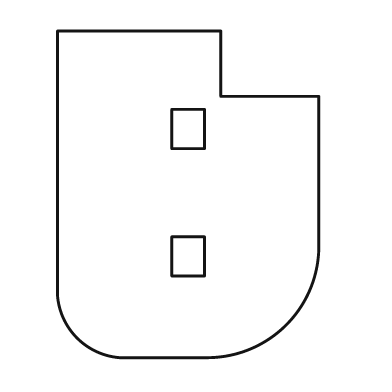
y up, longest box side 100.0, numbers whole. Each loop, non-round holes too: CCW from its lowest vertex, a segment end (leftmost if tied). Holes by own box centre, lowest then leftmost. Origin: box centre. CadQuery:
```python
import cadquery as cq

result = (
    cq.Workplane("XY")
    .moveTo(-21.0, -50.0)
    .lineTo(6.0, -50.0)
    .threePointArc((30.0, -40.0), (40.0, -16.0))
    .lineTo(40.0, 30.0)
    .lineTo(10.0, 30.0)
    .lineTo(10.0, 50.0)
    .lineTo(-40.0, 50.0)
    .lineTo(-40.0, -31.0)
    .threePointArc((-34.0, -44.0), (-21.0, -50.0))
    .close()
    .moveTo(-5.0, -25.0)
    .lineTo(5.0, -25.0)
    .lineTo(5.0, -13.0)
    .lineTo(-5.0, -13.0)
    .close()
    .moveTo(-5.0, 14.0)
    .lineTo(5.0, 14.0)
    .lineTo(5.0, 26.0)
    .lineTo(-5.0, 26.0)
    .close()
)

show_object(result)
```